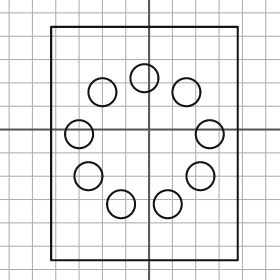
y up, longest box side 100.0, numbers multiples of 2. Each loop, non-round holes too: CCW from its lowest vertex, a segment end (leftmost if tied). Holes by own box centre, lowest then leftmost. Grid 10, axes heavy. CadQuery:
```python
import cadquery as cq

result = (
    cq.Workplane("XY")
    .moveTo(-42.0, -56.0)
    .lineTo(38.0, -56.0)
    .lineTo(38.0, 44.0)
    .lineTo(-42.0, 44.0)
    .close()
    .moveTo(-12.0, -32.0)
    .circle(6.0)
    .moveTo(8.0, -32.0)
    .circle(6.0)
    .moveTo(-26.0, -20.0)
    .circle(6.0)
    .moveTo(22.0, -20.0)
    .circle(6.0)
    .moveTo(-30.0, -2.0)
    .circle(6.0)
    .moveTo(26.0, -2.0)
    .circle(6.0)
    .moveTo(-20.0, 16.0)
    .circle(6.0)
    .moveTo(16.0, 16.0)
    .circle(6.0)
    .moveTo(-2.0, 22.0)
    .circle(6.0)
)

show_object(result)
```